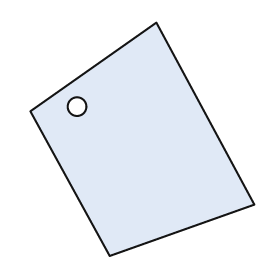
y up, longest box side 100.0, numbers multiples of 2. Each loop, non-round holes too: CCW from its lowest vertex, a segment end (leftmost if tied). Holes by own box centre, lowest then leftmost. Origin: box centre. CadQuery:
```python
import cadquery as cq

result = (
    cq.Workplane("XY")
    .moveTo(-14.0, -50.0)
    .lineTo(48.0, -28.0)
    .lineTo(6.0, 50.0)
    .lineTo(-48.0, 12.0)
    .close()
    .moveTo(-28.0, 14.0)
    .circle(4.0)
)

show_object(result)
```